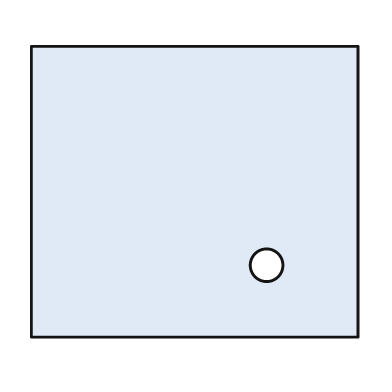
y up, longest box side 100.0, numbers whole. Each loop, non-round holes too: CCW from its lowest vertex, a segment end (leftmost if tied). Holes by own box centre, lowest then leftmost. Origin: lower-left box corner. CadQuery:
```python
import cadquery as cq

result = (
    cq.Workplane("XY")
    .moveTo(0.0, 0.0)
    .lineTo(100.0, 0.0)
    .lineTo(100.0, 89.0)
    .lineTo(0.0, 89.0)
    .close()
    .moveTo(72.0, 22.0)
    .circle(5.0)
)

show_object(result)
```